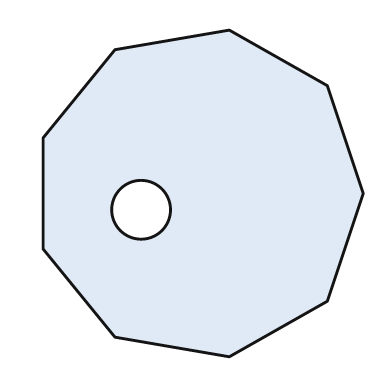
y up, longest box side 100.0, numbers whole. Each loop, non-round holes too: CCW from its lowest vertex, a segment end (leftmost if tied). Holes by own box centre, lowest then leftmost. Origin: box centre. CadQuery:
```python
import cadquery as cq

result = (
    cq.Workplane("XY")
    .moveTo(8.0, -50.0)
    .lineTo(38.0, -33.0)
    .lineTo(49.0, 0.0)
    .lineTo(38.0, 33.0)
    .lineTo(8.0, 50.0)
    .lineTo(-27.0, 44.0)
    .lineTo(-49.0, 17.0)
    .lineTo(-49.0, -17.0)
    .lineTo(-27.0, -44.0)
    .close()
    .moveTo(-19.0, -5.0)
    .circle(9.0)
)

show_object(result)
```